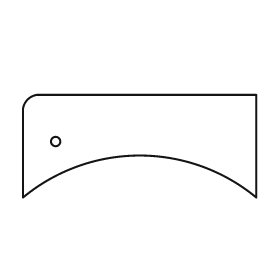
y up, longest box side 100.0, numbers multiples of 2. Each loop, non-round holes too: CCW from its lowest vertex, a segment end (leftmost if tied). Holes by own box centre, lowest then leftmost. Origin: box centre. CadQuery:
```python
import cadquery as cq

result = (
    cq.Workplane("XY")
    .moveTo(-50.0, -22.0)
    .threePointArc((0.0, -4.0), (50.0, -22.0))
    .lineTo(50.0, 22.0)
    .lineTo(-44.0, 22.0)
    .threePointArc((-48.0, 20.0), (-50.0, 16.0))
    .close()
    .moveTo(-36.0, 2.0)
    .circle(2.0)
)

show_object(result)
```